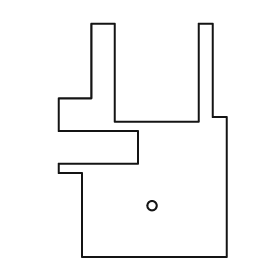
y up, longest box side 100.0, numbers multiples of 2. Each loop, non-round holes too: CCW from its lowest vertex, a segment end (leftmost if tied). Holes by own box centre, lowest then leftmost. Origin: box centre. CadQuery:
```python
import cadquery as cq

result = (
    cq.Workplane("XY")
    .moveTo(-26.0, -50.0)
    .lineTo(36.0, -50.0)
    .lineTo(36.0, 10.0)
    .lineTo(30.0, 10.0)
    .lineTo(30.0, 50.0)
    .lineTo(24.0, 50.0)
    .lineTo(24.0, 8.0)
    .lineTo(-12.0, 8.0)
    .lineTo(-12.0, 50.0)
    .lineTo(-22.0, 50.0)
    .lineTo(-22.0, 18.0)
    .lineTo(-36.0, 18.0)
    .lineTo(-36.0, 4.0)
    .lineTo(-2.0, 4.0)
    .lineTo(-2.0, -10.0)
    .lineTo(-36.0, -10.0)
    .lineTo(-36.0, -14.0)
    .lineTo(-26.0, -14.0)
    .close()
    .moveTo(4.0, -28.0)
    .circle(2.0)
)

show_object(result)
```